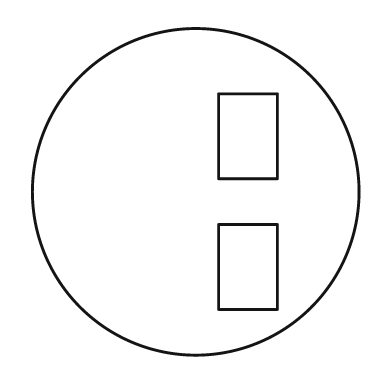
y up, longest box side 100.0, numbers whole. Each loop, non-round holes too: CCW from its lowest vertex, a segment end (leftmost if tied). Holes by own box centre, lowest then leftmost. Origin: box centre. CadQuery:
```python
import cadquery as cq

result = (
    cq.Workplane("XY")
    .moveTo(0.0, 0.0)
    .circle(50.0)
    .moveTo(7.0, -36.0)
    .lineTo(25.0, -36.0)
    .lineTo(25.0, -10.0)
    .lineTo(7.0, -10.0)
    .close()
    .moveTo(7.0, 4.0)
    .lineTo(25.0, 4.0)
    .lineTo(25.0, 30.0)
    .lineTo(7.0, 30.0)
    .close()
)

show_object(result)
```